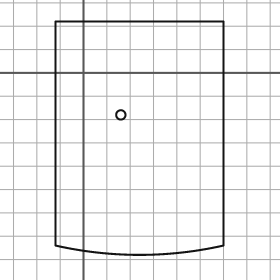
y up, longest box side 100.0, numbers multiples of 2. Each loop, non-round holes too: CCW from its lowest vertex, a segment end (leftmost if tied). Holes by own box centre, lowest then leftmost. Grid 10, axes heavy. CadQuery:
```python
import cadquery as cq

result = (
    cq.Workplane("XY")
    .moveTo(-12.0, -74.0)
    .threePointArc((24.0, -78.0), (60.0, -74.0))
    .lineTo(60.0, 22.0)
    .lineTo(-12.0, 22.0)
    .close()
    .moveTo(16.0, -18.0)
    .circle(2.0)
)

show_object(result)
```